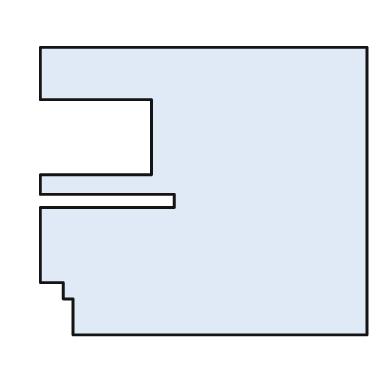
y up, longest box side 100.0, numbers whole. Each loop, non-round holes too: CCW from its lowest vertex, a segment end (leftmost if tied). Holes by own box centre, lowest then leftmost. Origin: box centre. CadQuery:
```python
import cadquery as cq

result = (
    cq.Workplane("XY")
    .moveTo(-40.0, -44.0)
    .lineTo(50.0, -44.0)
    .lineTo(50.0, 44.0)
    .lineTo(-50.0, 44.0)
    .lineTo(-50.0, 28.0)
    .lineTo(-16.0, 28.0)
    .lineTo(-16.0, 5.0)
    .lineTo(-50.0, 5.0)
    .lineTo(-50.0, -1.0)
    .lineTo(-9.0, -1.0)
    .lineTo(-9.0, -5.0)
    .lineTo(-50.0, -5.0)
    .lineTo(-50.0, -28.0)
    .lineTo(-43.0, -28.0)
    .lineTo(-43.0, -33.0)
    .lineTo(-40.0, -33.0)
    .close()
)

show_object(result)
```